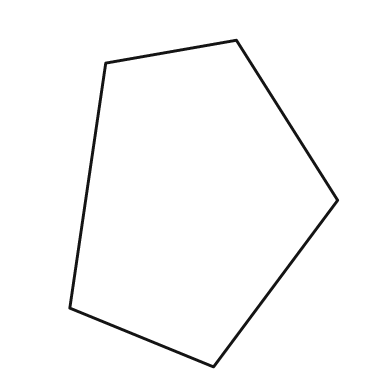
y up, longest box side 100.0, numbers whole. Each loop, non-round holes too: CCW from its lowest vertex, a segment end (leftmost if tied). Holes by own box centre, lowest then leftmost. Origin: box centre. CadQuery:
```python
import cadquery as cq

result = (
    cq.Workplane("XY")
    .moveTo(3.0, -50.0)
    .lineTo(41.0, 1.0)
    .lineTo(10.0, 50.0)
    .lineTo(-30.0, 43.0)
    .lineTo(-41.0, -32.0)
    .close()
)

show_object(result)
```